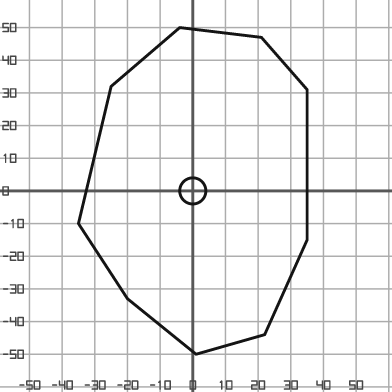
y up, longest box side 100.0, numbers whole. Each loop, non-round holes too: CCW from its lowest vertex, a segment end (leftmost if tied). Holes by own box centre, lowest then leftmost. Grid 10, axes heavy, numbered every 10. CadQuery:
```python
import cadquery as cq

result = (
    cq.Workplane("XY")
    .moveTo(1.0, -50.0)
    .lineTo(22.0, -44.0)
    .lineTo(35.0, -15.0)
    .lineTo(35.0, 31.0)
    .lineTo(21.0, 47.0)
    .lineTo(-4.0, 50.0)
    .lineTo(-25.0, 32.0)
    .lineTo(-35.0, -10.0)
    .lineTo(-20.0, -33.0)
    .close()
    .moveTo(0.0, 0.0)
    .circle(4.0)
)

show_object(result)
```